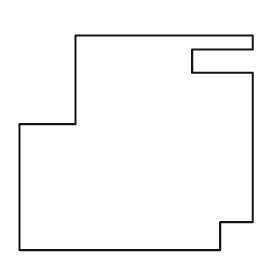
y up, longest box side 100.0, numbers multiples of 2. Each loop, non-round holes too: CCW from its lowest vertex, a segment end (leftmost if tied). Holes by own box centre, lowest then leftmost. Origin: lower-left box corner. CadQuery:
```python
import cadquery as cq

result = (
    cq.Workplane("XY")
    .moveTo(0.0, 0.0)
    .lineTo(86.0, 0.0)
    .lineTo(86.0, 12.0)
    .lineTo(100.0, 12.0)
    .lineTo(100.0, 76.0)
    .lineTo(74.0, 76.0)
    .lineTo(74.0, 86.0)
    .lineTo(100.0, 86.0)
    .lineTo(100.0, 92.0)
    .lineTo(24.0, 92.0)
    .lineTo(24.0, 54.0)
    .lineTo(0.0, 54.0)
    .close()
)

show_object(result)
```